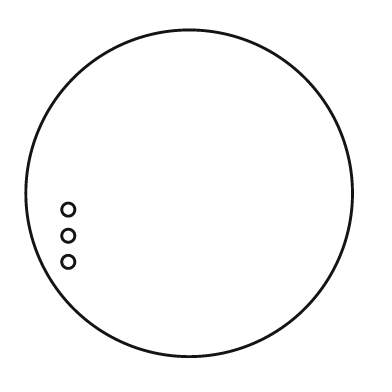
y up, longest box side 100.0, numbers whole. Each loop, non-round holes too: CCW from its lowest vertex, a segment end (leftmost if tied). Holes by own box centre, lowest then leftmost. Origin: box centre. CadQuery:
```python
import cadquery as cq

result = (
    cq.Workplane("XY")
    .moveTo(0.0, 0.0)
    .circle(50.0)
    .moveTo(-37.0, -21.0)
    .circle(2.0)
    .moveTo(-37.0, -13.0)
    .circle(2.0)
    .moveTo(-37.0, -5.0)
    .circle(2.0)
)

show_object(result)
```